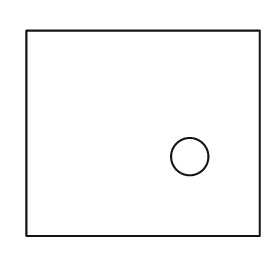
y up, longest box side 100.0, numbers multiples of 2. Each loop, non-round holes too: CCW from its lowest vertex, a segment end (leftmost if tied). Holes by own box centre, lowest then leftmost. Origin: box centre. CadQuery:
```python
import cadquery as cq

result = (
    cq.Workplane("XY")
    .moveTo(-50.0, -44.0)
    .lineTo(50.0, -44.0)
    .lineTo(50.0, 44.0)
    .lineTo(-50.0, 44.0)
    .close()
    .moveTo(20.0, -10.0)
    .circle(8.0)
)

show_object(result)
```